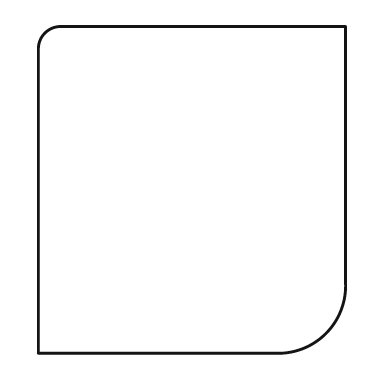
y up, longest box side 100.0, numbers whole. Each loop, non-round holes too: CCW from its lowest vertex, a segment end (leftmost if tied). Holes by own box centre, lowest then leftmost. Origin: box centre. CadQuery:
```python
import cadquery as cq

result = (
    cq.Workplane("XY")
    .moveTo(-47.0, -50.0)
    .lineTo(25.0, -50.0)
    .threePointArc((41.0, -44.0), (47.0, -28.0))
    .lineTo(47.0, 50.0)
    .lineTo(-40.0, 50.0)
    .threePointArc((-45.0, 48.0), (-47.0, 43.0))
    .close()
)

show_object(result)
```